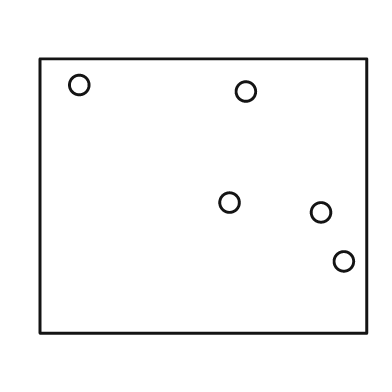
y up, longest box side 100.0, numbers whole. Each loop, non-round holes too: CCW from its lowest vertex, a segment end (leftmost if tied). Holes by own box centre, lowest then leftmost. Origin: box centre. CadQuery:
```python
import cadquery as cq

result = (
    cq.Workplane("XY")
    .moveTo(-50.0, -42.0)
    .lineTo(50.0, -42.0)
    .lineTo(50.0, 42.0)
    .lineTo(-50.0, 42.0)
    .close()
    .moveTo(43.0, -20.0)
    .circle(3.0)
    .moveTo(36.0, -5.0)
    .circle(3.0)
    .moveTo(8.0, -2.0)
    .circle(3.0)
    .moveTo(13.0, 32.0)
    .circle(3.0)
    .moveTo(-38.0, 34.0)
    .circle(3.0)
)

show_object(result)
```